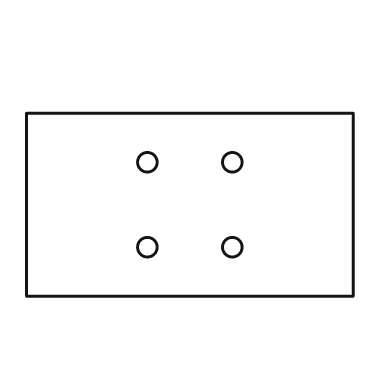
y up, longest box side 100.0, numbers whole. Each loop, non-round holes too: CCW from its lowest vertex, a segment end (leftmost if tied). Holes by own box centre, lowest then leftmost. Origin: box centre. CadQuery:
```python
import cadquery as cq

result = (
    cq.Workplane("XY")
    .moveTo(-50.0, -28.0)
    .lineTo(50.0, -28.0)
    .lineTo(50.0, 28.0)
    .lineTo(-50.0, 28.0)
    .close()
    .moveTo(-13.0, -13.0)
    .circle(3.0)
    .moveTo(13.0, -13.0)
    .circle(3.0)
    .moveTo(-13.0, 13.0)
    .circle(3.0)
    .moveTo(13.0, 13.0)
    .circle(3.0)
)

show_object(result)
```